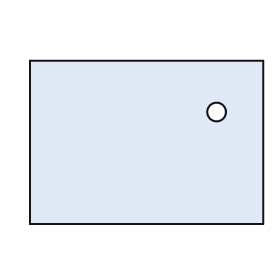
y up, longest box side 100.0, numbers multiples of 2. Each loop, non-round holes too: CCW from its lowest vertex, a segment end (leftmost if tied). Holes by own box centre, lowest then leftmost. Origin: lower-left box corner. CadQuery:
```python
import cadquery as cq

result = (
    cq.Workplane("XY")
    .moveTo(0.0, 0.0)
    .lineTo(100.0, 0.0)
    .lineTo(100.0, 70.0)
    .lineTo(0.0, 70.0)
    .close()
    .moveTo(80.0, 48.0)
    .circle(4.0)
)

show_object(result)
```